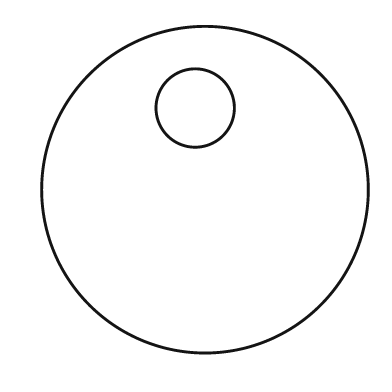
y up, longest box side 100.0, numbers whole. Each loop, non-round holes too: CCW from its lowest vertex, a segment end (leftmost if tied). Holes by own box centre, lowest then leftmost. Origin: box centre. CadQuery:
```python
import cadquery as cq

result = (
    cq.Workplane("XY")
    .moveTo(0.0, 0.0)
    .circle(50.0)
    .moveTo(-3.0, 25.0)
    .circle(12.0)
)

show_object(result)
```